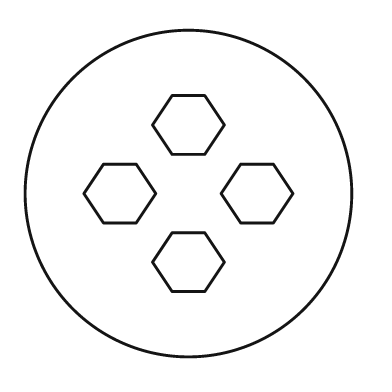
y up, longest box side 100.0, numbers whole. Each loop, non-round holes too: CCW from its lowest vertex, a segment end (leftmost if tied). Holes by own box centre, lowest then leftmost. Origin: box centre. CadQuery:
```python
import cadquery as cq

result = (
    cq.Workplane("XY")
    .moveTo(0.0, 0.0)
    .circle(50.0)
    .moveTo(-5.0, -30.0)
    .lineTo(5.0, -30.0)
    .lineTo(11.0, -21.0)
    .lineTo(5.0, -12.0)
    .lineTo(-5.0, -12.0)
    .lineTo(-11.0, -21.0)
    .close()
    .moveTo(-26.0, -9.0)
    .lineTo(-16.0, -9.0)
    .lineTo(-10.0, 0.0)
    .lineTo(-16.0, 9.0)
    .lineTo(-26.0, 9.0)
    .lineTo(-32.0, 0.0)
    .close()
    .moveTo(16.0, -9.0)
    .lineTo(26.0, -9.0)
    .lineTo(32.0, 0.0)
    .lineTo(26.0, 9.0)
    .lineTo(16.0, 9.0)
    .lineTo(10.0, 0.0)
    .close()
    .moveTo(-5.0, 12.0)
    .lineTo(5.0, 12.0)
    .lineTo(11.0, 21.0)
    .lineTo(5.0, 30.0)
    .lineTo(-5.0, 30.0)
    .lineTo(-11.0, 21.0)
    .close()
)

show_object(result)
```